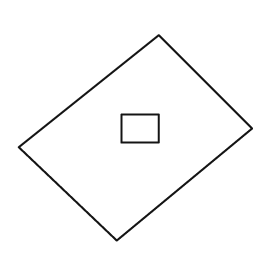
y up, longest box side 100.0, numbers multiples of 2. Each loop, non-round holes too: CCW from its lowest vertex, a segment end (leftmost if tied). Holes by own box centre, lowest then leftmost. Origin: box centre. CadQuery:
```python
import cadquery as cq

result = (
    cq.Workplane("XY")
    .moveTo(-8.0, -44.0)
    .lineTo(50.0, 4.0)
    .lineTo(10.0, 44.0)
    .lineTo(-50.0, -4.0)
    .close()
    .moveTo(-6.0, -2.0)
    .lineTo(10.0, -2.0)
    .lineTo(10.0, 10.0)
    .lineTo(-6.0, 10.0)
    .close()
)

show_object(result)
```